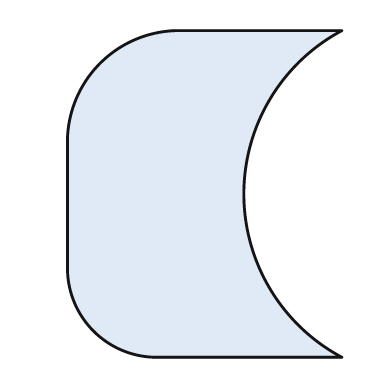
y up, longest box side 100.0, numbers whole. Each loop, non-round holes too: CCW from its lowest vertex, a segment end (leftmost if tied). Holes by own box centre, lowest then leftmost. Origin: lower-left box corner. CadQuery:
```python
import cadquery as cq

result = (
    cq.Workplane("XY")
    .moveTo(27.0, 0.0)
    .lineTo(84.0, 0.0)
    .threePointArc((54.0, 50.0), (84.0, 100.0))
    .lineTo(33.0, 100.0)
    .threePointArc((10.0, 90.0), (0.0, 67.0))
    .lineTo(0.0, 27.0)
    .threePointArc((8.0, 8.0), (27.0, 0.0))
    .close()
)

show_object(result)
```